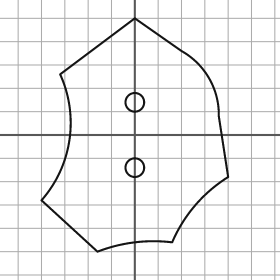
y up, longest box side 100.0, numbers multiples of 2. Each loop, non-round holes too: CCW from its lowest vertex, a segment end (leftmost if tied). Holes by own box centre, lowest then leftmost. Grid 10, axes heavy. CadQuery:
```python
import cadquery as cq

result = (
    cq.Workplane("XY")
    .moveTo(-16.0, -50.0)
    .threePointArc((0.0, -46.0), (16.0, -46.0))
    .threePointArc((26.0, -30.0), (40.0, -18.0))
    .lineTo(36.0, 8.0)
    .threePointArc((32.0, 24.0), (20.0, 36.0))
    .lineTo(0.0, 50.0)
    .lineTo(-32.0, 26.0)
    .threePointArc((-28.0, -2.0), (-40.0, -28.0))
    .close()
    .moveTo(0.0, -14.0)
    .circle(4.0)
    .moveTo(0.0, 14.0)
    .circle(4.0)
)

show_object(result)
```